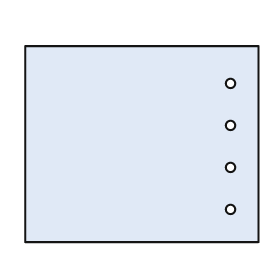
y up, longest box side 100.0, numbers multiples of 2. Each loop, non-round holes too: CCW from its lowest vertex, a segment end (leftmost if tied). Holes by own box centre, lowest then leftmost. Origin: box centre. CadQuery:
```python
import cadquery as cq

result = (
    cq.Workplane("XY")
    .moveTo(-50.0, -42.0)
    .lineTo(50.0, -42.0)
    .lineTo(50.0, 42.0)
    .lineTo(-50.0, 42.0)
    .close()
    .moveTo(38.0, -28.0)
    .circle(2.0)
    .moveTo(38.0, -10.0)
    .circle(2.0)
    .moveTo(38.0, 8.0)
    .circle(2.0)
    .moveTo(38.0, 26.0)
    .circle(2.0)
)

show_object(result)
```